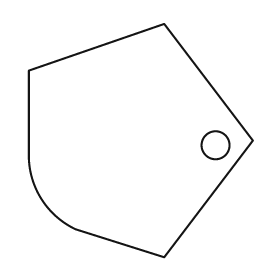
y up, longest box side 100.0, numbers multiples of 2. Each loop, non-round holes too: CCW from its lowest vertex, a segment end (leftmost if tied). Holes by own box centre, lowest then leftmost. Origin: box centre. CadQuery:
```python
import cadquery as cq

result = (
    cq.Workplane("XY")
    .moveTo(10.0, -50.0)
    .lineTo(48.0, 0.0)
    .lineTo(10.0, 50.0)
    .lineTo(-48.0, 30.0)
    .lineTo(-48.0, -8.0)
    .threePointArc((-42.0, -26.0), (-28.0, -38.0))
    .close()
    .moveTo(32.0, -2.0)
    .circle(6.0)
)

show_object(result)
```